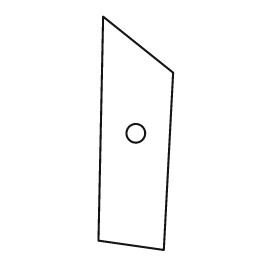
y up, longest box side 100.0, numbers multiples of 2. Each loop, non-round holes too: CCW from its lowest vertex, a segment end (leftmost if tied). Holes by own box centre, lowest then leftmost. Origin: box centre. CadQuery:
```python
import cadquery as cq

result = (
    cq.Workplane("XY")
    .moveTo(12.0, -50.0)
    .lineTo(16.0, 26.0)
    .lineTo(-14.0, 50.0)
    .lineTo(-16.0, -46.0)
    .close()
    .moveTo(0.0, 0.0)
    .circle(4.0)
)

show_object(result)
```